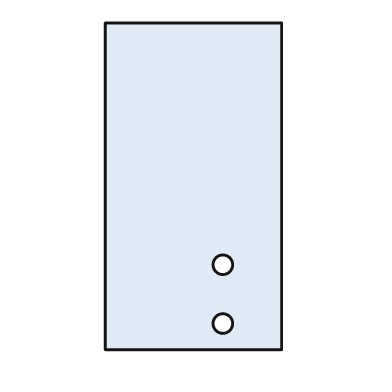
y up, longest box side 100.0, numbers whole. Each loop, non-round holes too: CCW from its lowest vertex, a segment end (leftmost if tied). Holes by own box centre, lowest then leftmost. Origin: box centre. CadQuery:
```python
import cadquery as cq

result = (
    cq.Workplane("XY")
    .moveTo(-27.0, -50.0)
    .lineTo(27.0, -50.0)
    .lineTo(27.0, 50.0)
    .lineTo(-27.0, 50.0)
    .close()
    .moveTo(9.0, -42.0)
    .circle(3.0)
    .moveTo(9.0, -24.0)
    .circle(3.0)
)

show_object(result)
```